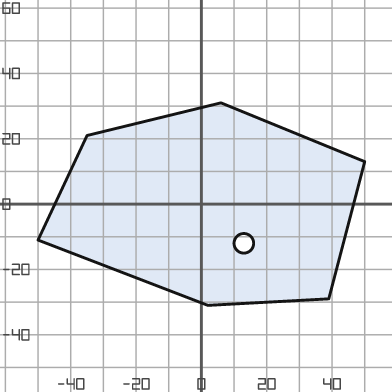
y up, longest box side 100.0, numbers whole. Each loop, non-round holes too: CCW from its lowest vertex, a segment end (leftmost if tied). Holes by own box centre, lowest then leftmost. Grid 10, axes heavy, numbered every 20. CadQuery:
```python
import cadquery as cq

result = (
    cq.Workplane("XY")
    .moveTo(2.0, -31.0)
    .lineTo(39.0, -29.0)
    .lineTo(50.0, 13.0)
    .lineTo(6.0, 31.0)
    .lineTo(-35.0, 21.0)
    .lineTo(-50.0, -11.0)
    .close()
    .moveTo(13.0, -12.0)
    .circle(3.0)
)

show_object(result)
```